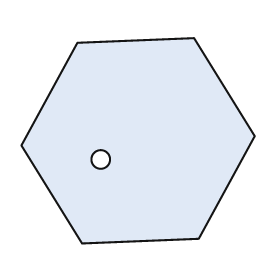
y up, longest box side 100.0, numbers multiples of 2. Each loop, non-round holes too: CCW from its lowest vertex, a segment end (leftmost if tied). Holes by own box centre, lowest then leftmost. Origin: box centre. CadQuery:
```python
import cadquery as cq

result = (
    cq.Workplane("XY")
    .moveTo(-24.0, -44.0)
    .lineTo(26.0, -42.0)
    .lineTo(50.0, 2.0)
    .lineTo(24.0, 44.0)
    .lineTo(-26.0, 42.0)
    .lineTo(-50.0, -2.0)
    .close()
    .moveTo(-16.0, -8.0)
    .circle(4.0)
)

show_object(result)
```